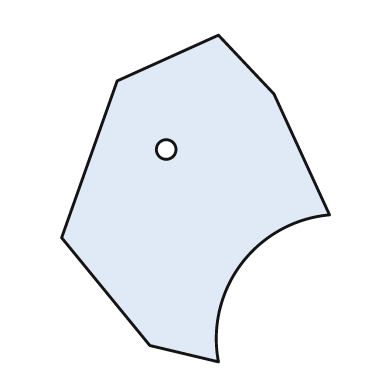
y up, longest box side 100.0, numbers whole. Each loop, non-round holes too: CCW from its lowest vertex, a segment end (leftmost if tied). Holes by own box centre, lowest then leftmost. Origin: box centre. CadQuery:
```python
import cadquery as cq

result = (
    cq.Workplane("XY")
    .moveTo(7.0, -50.0)
    .threePointArc((14.0, -20.0), (41.0, -5.0))
    .lineTo(24.0, 32.0)
    .lineTo(7.0, 50.0)
    .lineTo(-24.0, 36.0)
    .lineTo(-41.0, -12.0)
    .lineTo(-14.0, -45.0)
    .close()
    .moveTo(-9.0, 15.0)
    .circle(3.0)
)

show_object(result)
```